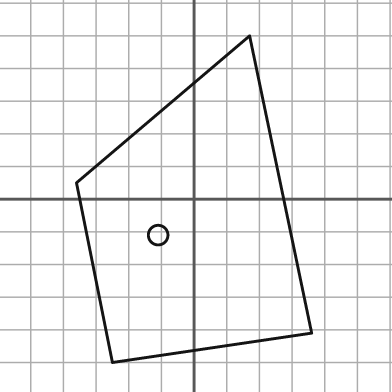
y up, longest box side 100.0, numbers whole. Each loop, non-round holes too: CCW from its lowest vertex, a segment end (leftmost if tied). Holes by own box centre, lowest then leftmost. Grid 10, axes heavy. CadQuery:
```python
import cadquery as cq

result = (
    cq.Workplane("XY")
    .moveTo(-25.0, -50.0)
    .lineTo(36.0, -41.0)
    .lineTo(17.0, 50.0)
    .lineTo(-36.0, 5.0)
    .close()
    .moveTo(-11.0, -11.0)
    .circle(3.0)
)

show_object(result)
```